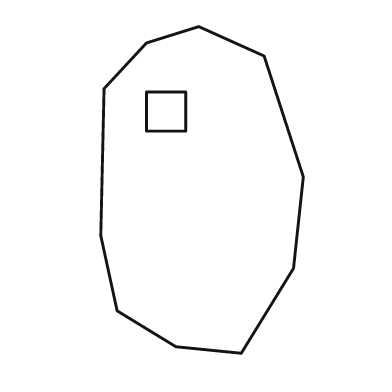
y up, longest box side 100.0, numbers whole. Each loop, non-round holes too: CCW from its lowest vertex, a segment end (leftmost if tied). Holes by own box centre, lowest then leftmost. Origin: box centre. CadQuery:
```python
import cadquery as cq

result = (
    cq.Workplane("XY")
    .moveTo(12.0, -50.0)
    .lineTo(28.0, -24.0)
    .lineTo(31.0, 4.0)
    .lineTo(19.0, 41.0)
    .lineTo(-1.0, 50.0)
    .lineTo(-17.0, 45.0)
    .lineTo(-30.0, 31.0)
    .lineTo(-31.0, -14.0)
    .lineTo(-26.0, -37.0)
    .lineTo(-8.0, -48.0)
    .close()
    .moveTo(-17.0, 18.0)
    .lineTo(-5.0, 18.0)
    .lineTo(-5.0, 30.0)
    .lineTo(-17.0, 30.0)
    .close()
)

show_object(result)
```